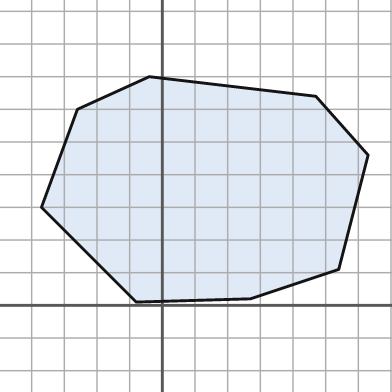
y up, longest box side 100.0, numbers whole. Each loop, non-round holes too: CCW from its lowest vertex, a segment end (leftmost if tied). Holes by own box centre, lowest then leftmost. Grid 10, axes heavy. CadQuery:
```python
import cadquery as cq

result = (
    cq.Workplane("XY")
    .moveTo(-8.0, 1.0)
    .lineTo(27.0, 2.0)
    .lineTo(54.0, 11.0)
    .lineTo(63.0, 46.0)
    .lineTo(47.0, 64.0)
    .lineTo(-4.0, 70.0)
    .lineTo(-26.0, 60.0)
    .lineTo(-37.0, 30.0)
    .close()
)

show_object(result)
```